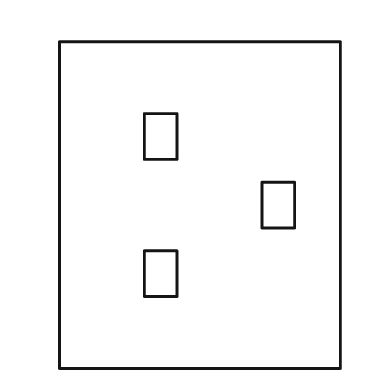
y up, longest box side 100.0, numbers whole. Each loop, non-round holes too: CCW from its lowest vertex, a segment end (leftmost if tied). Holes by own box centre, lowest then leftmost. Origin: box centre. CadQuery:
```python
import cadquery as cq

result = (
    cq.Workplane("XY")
    .moveTo(-43.0, -50.0)
    .lineTo(43.0, -50.0)
    .lineTo(43.0, 50.0)
    .lineTo(-43.0, 50.0)
    .close()
    .moveTo(-17.0, -28.0)
    .lineTo(-7.0, -28.0)
    .lineTo(-7.0, -14.0)
    .lineTo(-17.0, -14.0)
    .close()
    .moveTo(19.0, -7.0)
    .lineTo(29.0, -7.0)
    .lineTo(29.0, 7.0)
    .lineTo(19.0, 7.0)
    .close()
    .moveTo(-17.0, 14.0)
    .lineTo(-7.0, 14.0)
    .lineTo(-7.0, 28.0)
    .lineTo(-17.0, 28.0)
    .close()
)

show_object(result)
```